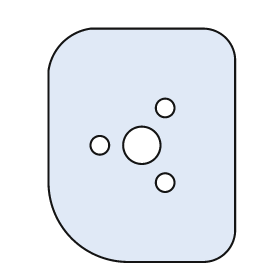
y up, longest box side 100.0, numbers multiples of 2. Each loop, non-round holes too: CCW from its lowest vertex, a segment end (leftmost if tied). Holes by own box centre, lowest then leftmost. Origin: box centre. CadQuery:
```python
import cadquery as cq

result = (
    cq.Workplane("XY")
    .moveTo(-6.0, -50.0)
    .lineTo(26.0, -50.0)
    .threePointArc((36.0, -46.0), (40.0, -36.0))
    .lineTo(40.0, 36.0)
    .threePointArc((36.0, 46.0), (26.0, 50.0))
    .lineTo(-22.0, 50.0)
    .threePointArc((-34.0, 44.0), (-40.0, 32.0))
    .lineTo(-40.0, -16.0)
    .threePointArc((-30.0, -40.0), (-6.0, -50.0))
    .close()
    .moveTo(10.0, -16.0)
    .circle(4.0)
    .moveTo(-18.0, 0.0)
    .circle(4.0)
    .moveTo(0.0, 0.0)
    .circle(8.0)
    .moveTo(10.0, 16.0)
    .circle(4.0)
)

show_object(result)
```